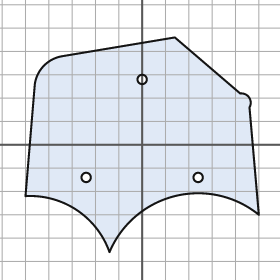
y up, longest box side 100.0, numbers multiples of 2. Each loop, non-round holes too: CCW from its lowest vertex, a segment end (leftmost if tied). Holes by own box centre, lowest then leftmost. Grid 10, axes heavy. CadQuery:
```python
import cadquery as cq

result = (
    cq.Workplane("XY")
    .moveTo(-14.0, -46.0)
    .threePointArc((14.0, -22.0), (50.0, -30.0))
    .lineTo(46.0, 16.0)
    .threePointArc((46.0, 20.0), (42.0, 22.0))
    .lineTo(14.0, 46.0)
    .lineTo(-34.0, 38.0)
    .threePointArc((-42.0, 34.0), (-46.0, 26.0))
    .lineTo(-50.0, -22.0)
    .threePointArc((-28.0, -28.0), (-14.0, -46.0))
    .close()
    .moveTo(-24.0, -14.0)
    .circle(2.0)
    .moveTo(24.0, -14.0)
    .circle(2.0)
    .moveTo(0.0, 28.0)
    .circle(2.0)
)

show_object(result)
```